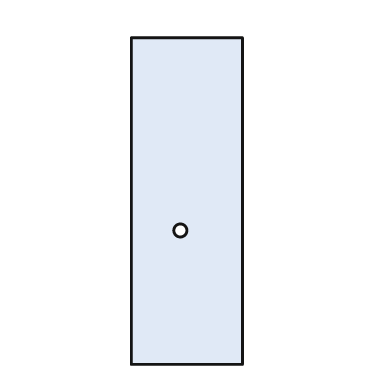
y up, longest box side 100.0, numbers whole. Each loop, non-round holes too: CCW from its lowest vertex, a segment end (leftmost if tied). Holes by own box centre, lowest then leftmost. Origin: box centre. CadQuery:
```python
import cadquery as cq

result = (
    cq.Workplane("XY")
    .moveTo(-17.0, -50.0)
    .lineTo(17.0, -50.0)
    .lineTo(17.0, 50.0)
    .lineTo(-17.0, 50.0)
    .close()
    .moveTo(-2.0, -9.0)
    .circle(2.0)
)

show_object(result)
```